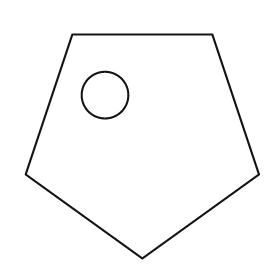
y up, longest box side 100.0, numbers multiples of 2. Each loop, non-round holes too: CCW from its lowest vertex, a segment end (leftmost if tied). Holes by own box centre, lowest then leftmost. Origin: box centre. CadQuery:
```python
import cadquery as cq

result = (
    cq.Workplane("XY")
    .moveTo(0.0, -48.0)
    .lineTo(50.0, -12.0)
    .lineTo(30.0, 48.0)
    .lineTo(-30.0, 48.0)
    .lineTo(-50.0, -12.0)
    .close()
    .moveTo(-16.0, 22.0)
    .circle(10.0)
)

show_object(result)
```